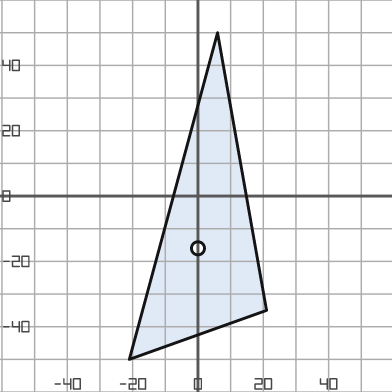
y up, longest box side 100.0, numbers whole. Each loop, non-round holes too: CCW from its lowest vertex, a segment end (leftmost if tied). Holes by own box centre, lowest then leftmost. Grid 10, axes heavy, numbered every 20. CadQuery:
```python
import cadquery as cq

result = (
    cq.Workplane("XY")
    .moveTo(-21.0, -50.0)
    .lineTo(21.0, -35.0)
    .lineTo(6.0, 50.0)
    .close()
    .moveTo(0.0, -16.0)
    .circle(2.0)
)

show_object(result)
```